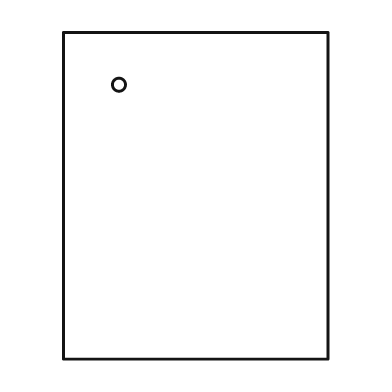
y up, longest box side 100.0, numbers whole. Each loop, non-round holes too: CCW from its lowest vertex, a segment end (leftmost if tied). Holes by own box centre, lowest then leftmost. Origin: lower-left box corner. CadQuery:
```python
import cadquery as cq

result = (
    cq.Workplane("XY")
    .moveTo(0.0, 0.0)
    .lineTo(81.0, 0.0)
    .lineTo(81.0, 100.0)
    .lineTo(0.0, 100.0)
    .close()
    .moveTo(17.0, 84.0)
    .circle(2.0)
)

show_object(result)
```